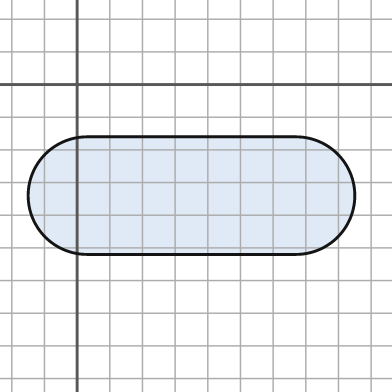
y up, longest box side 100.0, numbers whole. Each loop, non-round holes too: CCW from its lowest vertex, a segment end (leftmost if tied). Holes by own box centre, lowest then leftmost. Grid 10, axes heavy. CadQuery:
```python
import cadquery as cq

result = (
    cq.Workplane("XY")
    .moveTo(3.0, -52.0)
    .lineTo(67.0, -52.0)
    .threePointArc((85.0, -34.0), (67.0, -16.0))
    .lineTo(3.0, -16.0)
    .threePointArc((-15.0, -34.0), (3.0, -52.0))
    .close()
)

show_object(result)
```